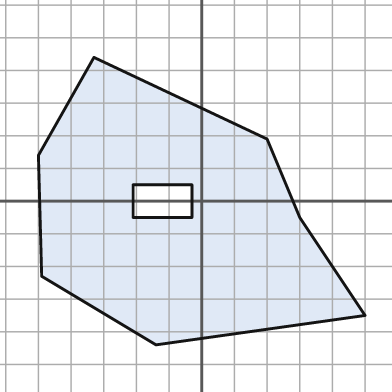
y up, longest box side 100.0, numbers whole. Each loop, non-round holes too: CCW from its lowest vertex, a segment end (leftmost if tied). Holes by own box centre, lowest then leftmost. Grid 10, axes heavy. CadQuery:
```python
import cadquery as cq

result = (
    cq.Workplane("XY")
    .moveTo(-14.0, -44.0)
    .lineTo(50.0, -35.0)
    .lineTo(30.0, -5.0)
    .lineTo(20.0, 19.0)
    .lineTo(-33.0, 44.0)
    .lineTo(-50.0, 14.0)
    .lineTo(-49.0, -23.0)
    .close()
    .moveTo(-21.0, -5.0)
    .lineTo(-3.0, -5.0)
    .lineTo(-3.0, 5.0)
    .lineTo(-21.0, 5.0)
    .close()
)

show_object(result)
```